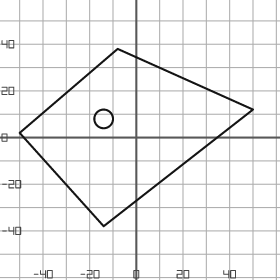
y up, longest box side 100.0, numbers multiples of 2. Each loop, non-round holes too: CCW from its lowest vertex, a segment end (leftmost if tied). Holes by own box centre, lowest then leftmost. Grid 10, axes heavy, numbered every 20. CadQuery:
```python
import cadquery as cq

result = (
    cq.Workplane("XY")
    .moveTo(-14.0, -38.0)
    .lineTo(50.0, 12.0)
    .lineTo(-8.0, 38.0)
    .lineTo(-50.0, 2.0)
    .close()
    .moveTo(-14.0, 8.0)
    .circle(4.0)
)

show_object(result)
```